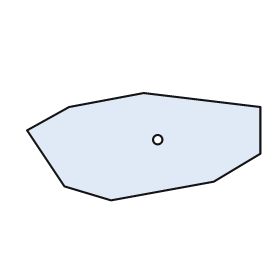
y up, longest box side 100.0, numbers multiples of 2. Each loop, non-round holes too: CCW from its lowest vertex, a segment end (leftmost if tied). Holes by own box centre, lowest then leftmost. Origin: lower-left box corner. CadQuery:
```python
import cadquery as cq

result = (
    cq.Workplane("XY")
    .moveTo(36.0, 0.0)
    .lineTo(80.0, 8.0)
    .lineTo(100.0, 20.0)
    .lineTo(100.0, 40.0)
    .lineTo(50.0, 46.0)
    .lineTo(18.0, 40.0)
    .lineTo(0.0, 30.0)
    .lineTo(16.0, 6.0)
    .close()
    .moveTo(56.0, 26.0)
    .circle(2.0)
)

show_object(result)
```